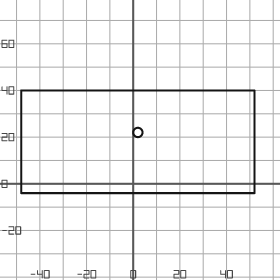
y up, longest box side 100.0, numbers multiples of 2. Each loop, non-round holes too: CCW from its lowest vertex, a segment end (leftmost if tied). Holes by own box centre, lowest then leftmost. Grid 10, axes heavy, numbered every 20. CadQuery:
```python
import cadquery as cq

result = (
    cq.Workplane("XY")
    .moveTo(-48.0, -4.0)
    .lineTo(52.0, -4.0)
    .lineTo(52.0, 40.0)
    .lineTo(-48.0, 40.0)
    .close()
    .moveTo(2.0, 22.0)
    .circle(2.0)
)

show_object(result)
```